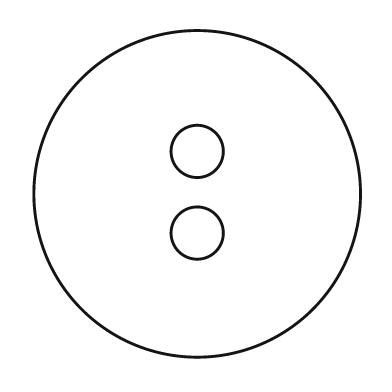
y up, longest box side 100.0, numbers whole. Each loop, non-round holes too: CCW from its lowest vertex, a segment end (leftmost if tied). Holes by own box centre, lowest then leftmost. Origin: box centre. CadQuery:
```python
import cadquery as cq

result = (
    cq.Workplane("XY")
    .moveTo(0.0, 0.0)
    .circle(50.0)
    .moveTo(0.0, -12.0)
    .circle(8.0)
    .moveTo(0.0, 13.0)
    .circle(8.0)
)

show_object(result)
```